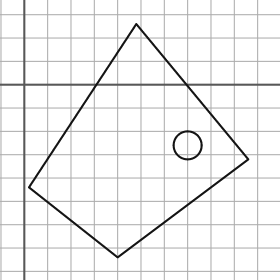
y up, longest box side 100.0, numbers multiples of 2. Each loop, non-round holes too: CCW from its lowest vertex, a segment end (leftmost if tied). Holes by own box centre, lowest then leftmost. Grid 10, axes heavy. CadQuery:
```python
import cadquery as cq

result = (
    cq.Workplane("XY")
    .moveTo(40.0, -74.0)
    .lineTo(96.0, -32.0)
    .lineTo(48.0, 26.0)
    .lineTo(2.0, -44.0)
    .close()
    .moveTo(70.0, -26.0)
    .circle(6.0)
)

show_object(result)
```